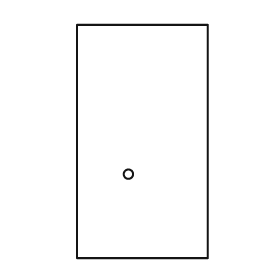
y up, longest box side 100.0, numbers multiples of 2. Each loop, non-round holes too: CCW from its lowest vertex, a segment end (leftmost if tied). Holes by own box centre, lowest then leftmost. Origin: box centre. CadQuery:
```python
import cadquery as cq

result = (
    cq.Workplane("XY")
    .moveTo(-28.0, -50.0)
    .lineTo(28.0, -50.0)
    .lineTo(28.0, 50.0)
    .lineTo(-28.0, 50.0)
    .close()
    .moveTo(-6.0, -14.0)
    .circle(2.0)
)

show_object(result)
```